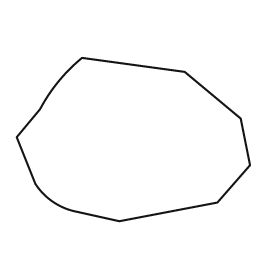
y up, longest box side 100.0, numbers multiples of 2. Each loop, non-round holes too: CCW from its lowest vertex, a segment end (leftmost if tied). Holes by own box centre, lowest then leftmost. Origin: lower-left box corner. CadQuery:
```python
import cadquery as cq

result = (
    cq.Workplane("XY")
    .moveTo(44.0, 0.0)
    .lineTo(86.0, 8.0)
    .lineTo(100.0, 24.0)
    .lineTo(96.0, 44.0)
    .lineTo(72.0, 64.0)
    .lineTo(28.0, 70.0)
    .threePointArc((18.0, 60.0), (10.0, 48.0))
    .lineTo(0.0, 36.0)
    .lineTo(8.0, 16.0)
    .threePointArc((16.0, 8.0), (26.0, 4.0))
    .close()
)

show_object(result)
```